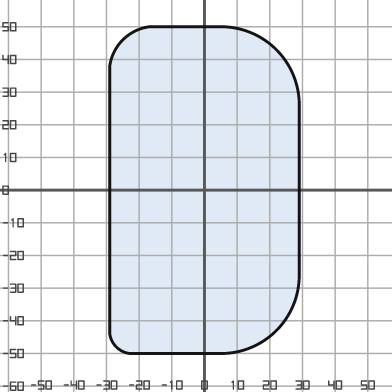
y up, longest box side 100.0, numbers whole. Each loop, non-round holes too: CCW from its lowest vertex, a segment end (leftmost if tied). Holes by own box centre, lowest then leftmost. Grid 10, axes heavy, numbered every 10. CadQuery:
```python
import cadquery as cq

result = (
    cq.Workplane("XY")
    .moveTo(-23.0, -50.0)
    .lineTo(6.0, -50.0)
    .threePointArc((22.0, -43.0), (29.0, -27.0))
    .lineTo(29.0, 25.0)
    .threePointArc((22.0, 43.0), (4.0, 50.0))
    .lineTo(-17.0, 50.0)
    .threePointArc((-25.0, 46.0), (-29.0, 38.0))
    .lineTo(-29.0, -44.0)
    .threePointArc((-27.0, -48.0), (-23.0, -50.0))
    .close()
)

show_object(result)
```